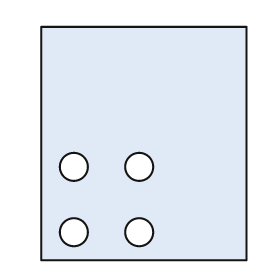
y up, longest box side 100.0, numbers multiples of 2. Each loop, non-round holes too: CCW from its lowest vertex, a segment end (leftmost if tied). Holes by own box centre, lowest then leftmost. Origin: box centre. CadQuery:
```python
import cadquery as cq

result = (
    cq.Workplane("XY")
    .moveTo(-44.0, -50.0)
    .lineTo(44.0, -50.0)
    .lineTo(44.0, 50.0)
    .lineTo(-44.0, 50.0)
    .close()
    .moveTo(-30.0, -38.0)
    .circle(6.0)
    .moveTo(-2.0, -38.0)
    .circle(6.0)
    .moveTo(-30.0, -10.0)
    .circle(6.0)
    .moveTo(-2.0, -10.0)
    .circle(6.0)
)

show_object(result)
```